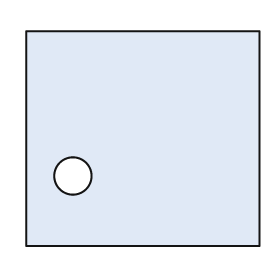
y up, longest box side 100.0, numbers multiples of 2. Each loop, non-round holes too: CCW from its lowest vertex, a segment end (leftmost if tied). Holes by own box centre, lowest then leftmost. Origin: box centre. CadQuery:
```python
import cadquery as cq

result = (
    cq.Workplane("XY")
    .moveTo(-50.0, -46.0)
    .lineTo(50.0, -46.0)
    .lineTo(50.0, 46.0)
    .lineTo(-50.0, 46.0)
    .close()
    .moveTo(-30.0, -16.0)
    .circle(8.0)
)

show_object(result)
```